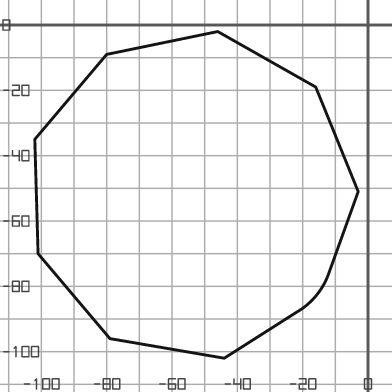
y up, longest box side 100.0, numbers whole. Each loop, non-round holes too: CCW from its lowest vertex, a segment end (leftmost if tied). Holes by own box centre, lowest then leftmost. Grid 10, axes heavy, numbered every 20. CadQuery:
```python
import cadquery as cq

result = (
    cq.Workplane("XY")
    .moveTo(-44.0, -102.0)
    .lineTo(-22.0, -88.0)
    .threePointArc((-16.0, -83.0), (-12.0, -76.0))
    .lineTo(-3.0, -51.0)
    .lineTo(-16.0, -19.0)
    .lineTo(-46.0, -2.0)
    .lineTo(-80.0, -9.0)
    .lineTo(-102.0, -35.0)
    .lineTo(-101.0, -70.0)
    .lineTo(-79.0, -96.0)
    .close()
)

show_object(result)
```